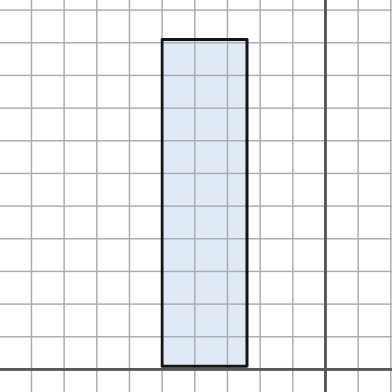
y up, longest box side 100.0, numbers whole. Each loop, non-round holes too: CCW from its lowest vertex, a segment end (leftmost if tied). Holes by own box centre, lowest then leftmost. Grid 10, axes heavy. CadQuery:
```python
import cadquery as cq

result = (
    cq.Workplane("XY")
    .moveTo(-50.0, 1.0)
    .lineTo(-24.0, 1.0)
    .lineTo(-24.0, 101.0)
    .lineTo(-50.0, 101.0)
    .close()
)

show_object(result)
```